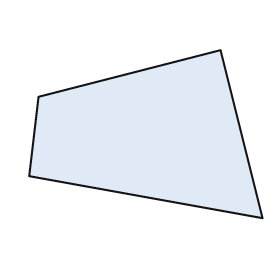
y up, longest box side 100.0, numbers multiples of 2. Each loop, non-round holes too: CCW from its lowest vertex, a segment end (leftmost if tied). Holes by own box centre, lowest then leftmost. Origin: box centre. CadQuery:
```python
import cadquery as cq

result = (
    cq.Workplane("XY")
    .moveTo(50.0, -36.0)
    .lineTo(32.0, 36.0)
    .lineTo(-46.0, 16.0)
    .lineTo(-50.0, -18.0)
    .close()
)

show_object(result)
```